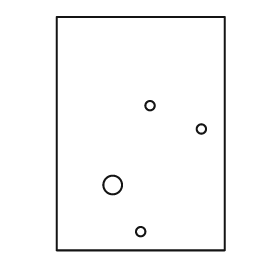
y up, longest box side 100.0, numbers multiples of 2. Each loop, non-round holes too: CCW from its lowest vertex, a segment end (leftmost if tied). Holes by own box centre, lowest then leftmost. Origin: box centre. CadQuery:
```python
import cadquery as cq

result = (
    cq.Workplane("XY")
    .moveTo(-36.0, -50.0)
    .lineTo(36.0, -50.0)
    .lineTo(36.0, 50.0)
    .lineTo(-36.0, 50.0)
    .close()
    .moveTo(0.0, -42.0)
    .circle(2.0)
    .moveTo(-12.0, -22.0)
    .circle(4.0)
    .moveTo(26.0, 2.0)
    .circle(2.0)
    .moveTo(4.0, 12.0)
    .circle(2.0)
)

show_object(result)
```